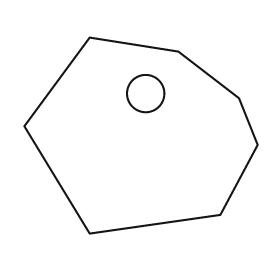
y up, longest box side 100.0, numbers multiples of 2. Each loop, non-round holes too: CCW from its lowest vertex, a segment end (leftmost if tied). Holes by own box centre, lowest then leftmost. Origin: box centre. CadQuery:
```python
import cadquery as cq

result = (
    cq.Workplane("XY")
    .moveTo(-22.0, -42.0)
    .lineTo(34.0, -34.0)
    .lineTo(50.0, -4.0)
    .lineTo(42.0, 16.0)
    .lineTo(16.0, 36.0)
    .lineTo(-22.0, 42.0)
    .lineTo(-50.0, 4.0)
    .close()
    .moveTo(2.0, 18.0)
    .circle(8.0)
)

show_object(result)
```